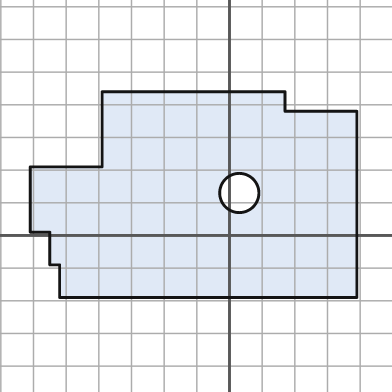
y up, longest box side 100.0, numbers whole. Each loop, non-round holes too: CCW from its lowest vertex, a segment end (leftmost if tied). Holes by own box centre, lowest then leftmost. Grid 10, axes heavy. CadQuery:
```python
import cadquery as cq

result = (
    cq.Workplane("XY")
    .moveTo(-52.0, -19.0)
    .lineTo(39.0, -19.0)
    .lineTo(39.0, 38.0)
    .lineTo(17.0, 38.0)
    .lineTo(17.0, 44.0)
    .lineTo(-39.0, 44.0)
    .lineTo(-39.0, 21.0)
    .lineTo(-61.0, 21.0)
    .lineTo(-61.0, 1.0)
    .lineTo(-55.0, 1.0)
    .lineTo(-55.0, -9.0)
    .lineTo(-52.0, -9.0)
    .close()
    .moveTo(3.0, 13.0)
    .circle(6.0)
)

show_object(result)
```